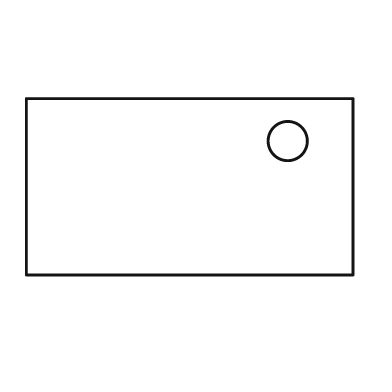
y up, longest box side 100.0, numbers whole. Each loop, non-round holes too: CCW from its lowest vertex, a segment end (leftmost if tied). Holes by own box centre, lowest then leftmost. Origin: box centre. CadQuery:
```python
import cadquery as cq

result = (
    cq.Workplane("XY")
    .moveTo(-50.0, -27.0)
    .lineTo(50.0, -27.0)
    .lineTo(50.0, 27.0)
    .lineTo(-50.0, 27.0)
    .close()
    .moveTo(30.0, 14.0)
    .circle(6.0)
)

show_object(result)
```